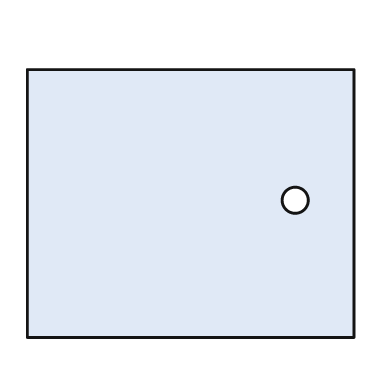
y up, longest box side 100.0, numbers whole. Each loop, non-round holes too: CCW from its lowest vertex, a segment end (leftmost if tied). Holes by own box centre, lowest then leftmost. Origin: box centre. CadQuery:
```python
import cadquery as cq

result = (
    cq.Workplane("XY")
    .moveTo(-50.0, -41.0)
    .lineTo(50.0, -41.0)
    .lineTo(50.0, 41.0)
    .lineTo(-50.0, 41.0)
    .close()
    .moveTo(32.0, 1.0)
    .circle(4.0)
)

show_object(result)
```